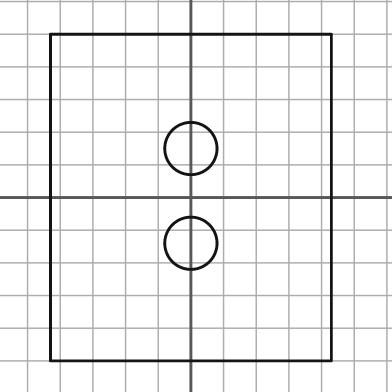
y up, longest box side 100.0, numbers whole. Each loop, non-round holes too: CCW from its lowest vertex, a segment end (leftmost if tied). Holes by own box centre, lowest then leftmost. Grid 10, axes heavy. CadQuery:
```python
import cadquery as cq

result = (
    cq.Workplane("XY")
    .moveTo(-43.0, -50.0)
    .lineTo(43.0, -50.0)
    .lineTo(43.0, 50.0)
    .lineTo(-43.0, 50.0)
    .close()
    .moveTo(0.0, -14.0)
    .circle(8.0)
    .moveTo(0.0, 15.0)
    .circle(8.0)
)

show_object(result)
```